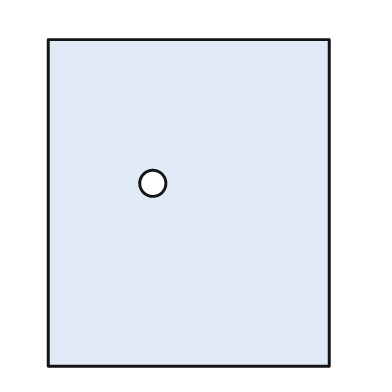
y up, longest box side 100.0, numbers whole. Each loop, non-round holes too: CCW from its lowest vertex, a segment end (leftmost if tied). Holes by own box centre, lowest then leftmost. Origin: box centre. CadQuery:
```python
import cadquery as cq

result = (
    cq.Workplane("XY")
    .moveTo(-43.0, -50.0)
    .lineTo(43.0, -50.0)
    .lineTo(43.0, 50.0)
    .lineTo(-43.0, 50.0)
    .close()
    .moveTo(-11.0, 6.0)
    .circle(4.0)
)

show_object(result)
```